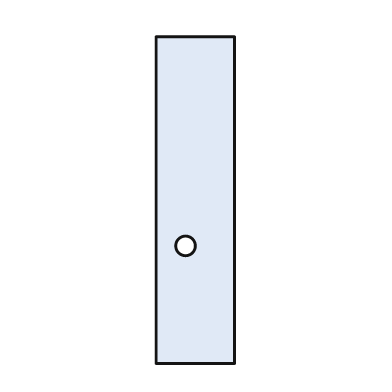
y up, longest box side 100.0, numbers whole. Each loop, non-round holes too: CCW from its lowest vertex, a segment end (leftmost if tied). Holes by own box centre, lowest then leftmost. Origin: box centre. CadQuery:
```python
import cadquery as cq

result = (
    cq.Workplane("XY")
    .moveTo(-12.0, -50.0)
    .lineTo(12.0, -50.0)
    .lineTo(12.0, 50.0)
    .lineTo(-12.0, 50.0)
    .close()
    .moveTo(-3.0, -14.0)
    .circle(3.0)
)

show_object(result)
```